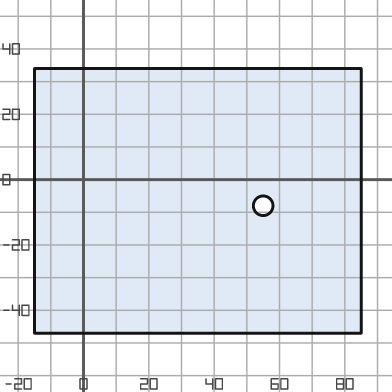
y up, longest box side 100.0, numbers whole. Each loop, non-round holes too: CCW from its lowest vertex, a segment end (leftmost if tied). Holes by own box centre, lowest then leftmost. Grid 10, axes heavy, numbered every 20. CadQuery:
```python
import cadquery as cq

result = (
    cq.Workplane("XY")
    .moveTo(-15.0, -47.0)
    .lineTo(85.0, -47.0)
    .lineTo(85.0, 34.0)
    .lineTo(-15.0, 34.0)
    .close()
    .moveTo(55.0, -8.0)
    .circle(3.0)
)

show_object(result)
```